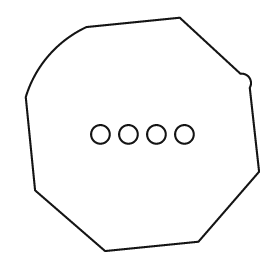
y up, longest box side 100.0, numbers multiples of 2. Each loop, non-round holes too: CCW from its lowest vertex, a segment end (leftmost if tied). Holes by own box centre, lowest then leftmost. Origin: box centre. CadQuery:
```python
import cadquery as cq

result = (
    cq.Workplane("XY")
    .moveTo(-16.0, -50.0)
    .lineTo(24.0, -46.0)
    .lineTo(50.0, -16.0)
    .lineTo(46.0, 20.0)
    .threePointArc((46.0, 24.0), (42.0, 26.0))
    .lineTo(16.0, 50.0)
    .lineTo(-24.0, 46.0)
    .threePointArc((-40.0, 34.0), (-50.0, 16.0))
    .lineTo(-46.0, -24.0)
    .close()
    .moveTo(-18.0, 0.0)
    .circle(4.0)
    .moveTo(-6.0, 0.0)
    .circle(4.0)
    .moveTo(6.0, 0.0)
    .circle(4.0)
    .moveTo(18.0, 0.0)
    .circle(4.0)
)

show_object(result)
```